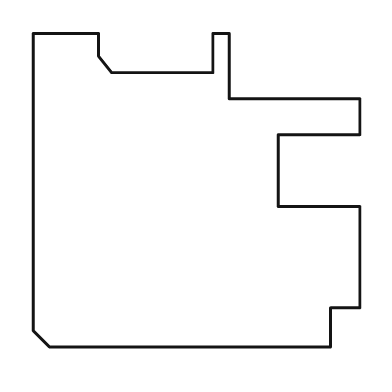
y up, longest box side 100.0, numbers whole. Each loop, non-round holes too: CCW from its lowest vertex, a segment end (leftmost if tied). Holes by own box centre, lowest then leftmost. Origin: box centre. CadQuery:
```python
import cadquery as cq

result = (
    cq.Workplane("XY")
    .moveTo(-45.0, -48.0)
    .lineTo(41.0, -48.0)
    .lineTo(41.0, -36.0)
    .lineTo(50.0, -36.0)
    .lineTo(50.0, -5.0)
    .lineTo(25.0, -5.0)
    .lineTo(25.0, 17.0)
    .lineTo(50.0, 17.0)
    .lineTo(50.0, 28.0)
    .lineTo(10.0, 28.0)
    .lineTo(10.0, 48.0)
    .lineTo(5.0, 48.0)
    .lineTo(5.0, 36.0)
    .lineTo(-26.0, 36.0)
    .lineTo(-30.0, 41.0)
    .lineTo(-30.0, 48.0)
    .lineTo(-50.0, 48.0)
    .lineTo(-50.0, -43.0)
    .close()
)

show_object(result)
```